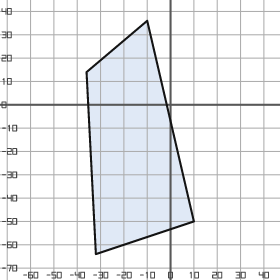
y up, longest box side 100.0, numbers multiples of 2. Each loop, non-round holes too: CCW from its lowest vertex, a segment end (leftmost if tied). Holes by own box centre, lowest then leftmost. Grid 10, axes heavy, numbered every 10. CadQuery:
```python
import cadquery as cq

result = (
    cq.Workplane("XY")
    .moveTo(-32.0, -64.0)
    .lineTo(10.0, -50.0)
    .lineTo(-10.0, 36.0)
    .lineTo(-36.0, 14.0)
    .close()
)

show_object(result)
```